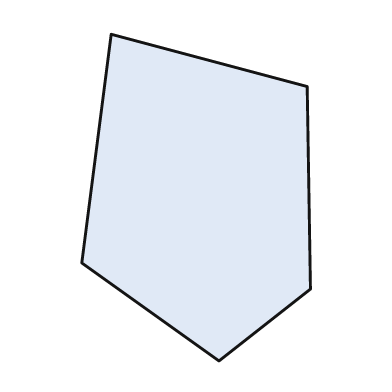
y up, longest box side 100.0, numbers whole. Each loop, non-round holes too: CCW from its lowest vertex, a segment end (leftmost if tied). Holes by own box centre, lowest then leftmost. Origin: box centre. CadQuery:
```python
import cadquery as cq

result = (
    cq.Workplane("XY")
    .moveTo(7.0, -50.0)
    .lineTo(35.0, -28.0)
    .lineTo(34.0, 34.0)
    .lineTo(-26.0, 50.0)
    .lineTo(-35.0, -20.0)
    .close()
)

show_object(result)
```